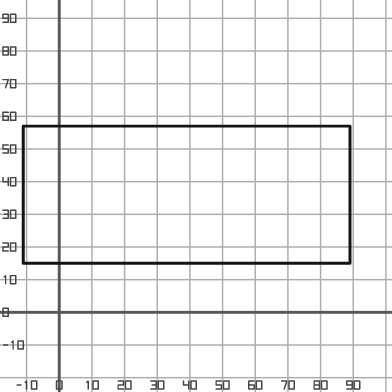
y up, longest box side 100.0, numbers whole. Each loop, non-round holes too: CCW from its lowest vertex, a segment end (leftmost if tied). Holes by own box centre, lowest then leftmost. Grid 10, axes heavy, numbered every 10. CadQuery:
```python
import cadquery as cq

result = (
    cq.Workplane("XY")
    .moveTo(-11.0, 15.0)
    .lineTo(89.0, 15.0)
    .lineTo(89.0, 57.0)
    .lineTo(-11.0, 57.0)
    .close()
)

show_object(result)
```